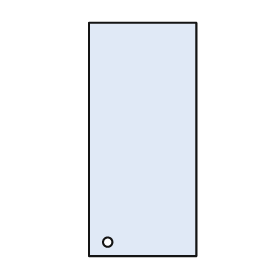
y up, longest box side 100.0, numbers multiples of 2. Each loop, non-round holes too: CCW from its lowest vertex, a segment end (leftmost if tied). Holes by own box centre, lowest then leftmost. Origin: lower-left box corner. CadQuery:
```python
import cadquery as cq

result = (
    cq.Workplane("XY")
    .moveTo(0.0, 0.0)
    .lineTo(46.0, 0.0)
    .lineTo(46.0, 100.0)
    .lineTo(0.0, 100.0)
    .close()
    .moveTo(8.0, 6.0)
    .circle(2.0)
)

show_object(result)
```